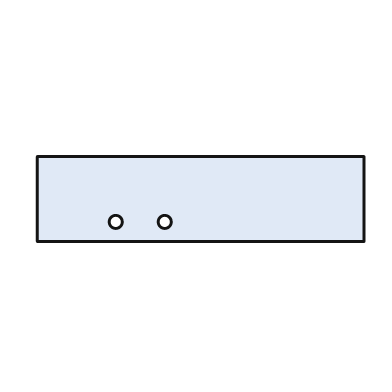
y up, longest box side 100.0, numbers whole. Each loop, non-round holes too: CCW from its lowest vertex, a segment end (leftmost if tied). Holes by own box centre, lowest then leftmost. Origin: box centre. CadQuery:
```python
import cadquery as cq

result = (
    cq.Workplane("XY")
    .moveTo(-50.0, -13.0)
    .lineTo(50.0, -13.0)
    .lineTo(50.0, 13.0)
    .lineTo(-50.0, 13.0)
    .close()
    .moveTo(-26.0, -7.0)
    .circle(2.0)
    .moveTo(-11.0, -7.0)
    .circle(2.0)
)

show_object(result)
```